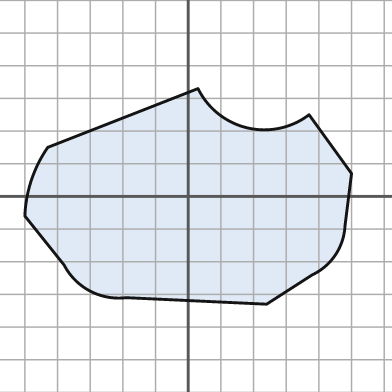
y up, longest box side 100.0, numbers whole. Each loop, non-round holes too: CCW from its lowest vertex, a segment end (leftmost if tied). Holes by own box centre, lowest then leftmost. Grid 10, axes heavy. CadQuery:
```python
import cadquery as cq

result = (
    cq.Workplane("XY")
    .moveTo(24.0, -33.0)
    .lineTo(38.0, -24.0)
    .threePointArc((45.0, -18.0), (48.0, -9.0))
    .lineTo(50.0, 7.0)
    .lineTo(37.0, 25.0)
    .threePointArc((18.0, 21.0), (3.0, 33.0))
    .lineTo(-43.0, 15.0)
    .threePointArc((-48.0, 5.0), (-50.0, -6.0))
    .lineTo(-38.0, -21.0)
    .threePointArc((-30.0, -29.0), (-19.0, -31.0))
    .close()
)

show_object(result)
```